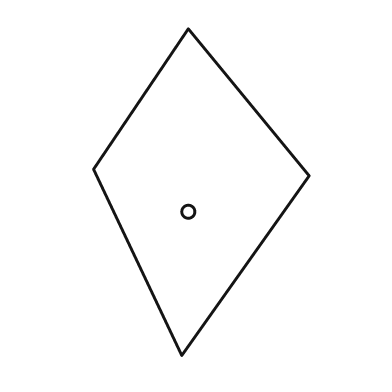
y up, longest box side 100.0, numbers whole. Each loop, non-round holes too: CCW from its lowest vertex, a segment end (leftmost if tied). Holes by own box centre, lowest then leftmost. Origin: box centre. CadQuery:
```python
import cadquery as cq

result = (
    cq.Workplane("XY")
    .moveTo(-6.0, -50.0)
    .lineTo(33.0, 5.0)
    .lineTo(-4.0, 50.0)
    .lineTo(-33.0, 7.0)
    .close()
    .moveTo(-4.0, -6.0)
    .circle(2.0)
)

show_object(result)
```